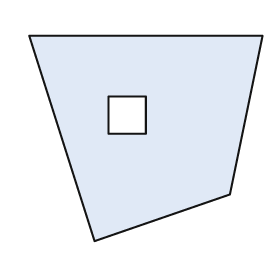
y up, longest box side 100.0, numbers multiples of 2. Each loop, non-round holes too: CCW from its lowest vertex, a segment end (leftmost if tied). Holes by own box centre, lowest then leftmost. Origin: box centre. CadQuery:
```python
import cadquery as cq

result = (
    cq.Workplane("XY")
    .moveTo(-22.0, -44.0)
    .lineTo(36.0, -24.0)
    .lineTo(50.0, 44.0)
    .lineTo(-50.0, 44.0)
    .close()
    .moveTo(-16.0, 2.0)
    .lineTo(0.0, 2.0)
    .lineTo(0.0, 18.0)
    .lineTo(-16.0, 18.0)
    .close()
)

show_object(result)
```